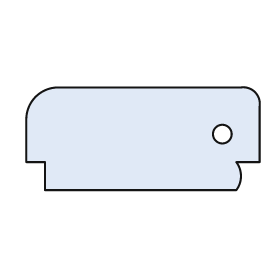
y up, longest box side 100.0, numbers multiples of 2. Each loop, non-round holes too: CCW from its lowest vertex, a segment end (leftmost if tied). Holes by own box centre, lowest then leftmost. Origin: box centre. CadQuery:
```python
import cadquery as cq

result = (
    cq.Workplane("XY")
    .moveTo(-42.0, -22.0)
    .lineTo(40.0, -22.0)
    .threePointArc((42.0, -16.0), (40.0, -10.0))
    .lineTo(50.0, -10.0)
    .lineTo(50.0, 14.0)
    .threePointArc((48.0, 20.0), (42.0, 22.0))
    .lineTo(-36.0, 22.0)
    .threePointArc((-46.0, 18.0), (-50.0, 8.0))
    .lineTo(-50.0, -10.0)
    .lineTo(-42.0, -10.0)
    .close()
    .moveTo(34.0, 2.0)
    .circle(4.0)
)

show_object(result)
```